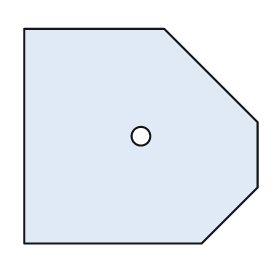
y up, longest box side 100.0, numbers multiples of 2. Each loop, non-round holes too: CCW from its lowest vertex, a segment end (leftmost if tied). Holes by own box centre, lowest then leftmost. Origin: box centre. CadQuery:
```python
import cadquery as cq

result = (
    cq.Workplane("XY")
    .moveTo(-50.0, -46.0)
    .lineTo(26.0, -46.0)
    .lineTo(50.0, -22.0)
    .lineTo(50.0, 6.0)
    .lineTo(10.0, 46.0)
    .lineTo(-50.0, 46.0)
    .close()
    .moveTo(0.0, 0.0)
    .circle(4.0)
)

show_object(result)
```